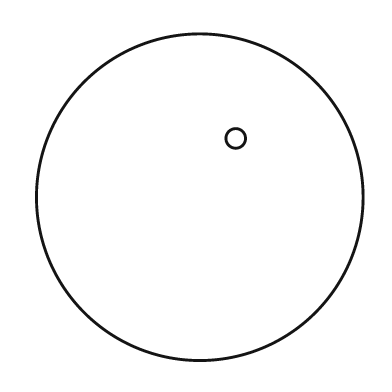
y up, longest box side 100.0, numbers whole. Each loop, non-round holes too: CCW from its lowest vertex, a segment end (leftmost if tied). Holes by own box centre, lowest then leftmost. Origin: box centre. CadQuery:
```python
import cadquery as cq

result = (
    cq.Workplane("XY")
    .moveTo(0.0, 0.0)
    .circle(50.0)
    .moveTo(11.0, 18.0)
    .circle(3.0)
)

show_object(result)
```